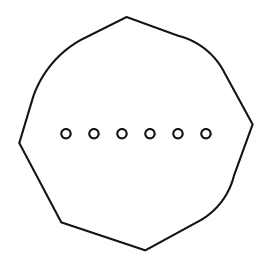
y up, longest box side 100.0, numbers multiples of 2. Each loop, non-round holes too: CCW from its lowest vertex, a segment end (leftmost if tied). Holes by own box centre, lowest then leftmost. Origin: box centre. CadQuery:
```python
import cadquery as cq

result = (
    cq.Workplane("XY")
    .moveTo(4.0, -50.0)
    .lineTo(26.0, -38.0)
    .threePointArc((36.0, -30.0), (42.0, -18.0))
    .lineTo(50.0, 4.0)
    .lineTo(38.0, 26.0)
    .threePointArc((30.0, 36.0), (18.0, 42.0))
    .lineTo(-4.0, 50.0)
    .lineTo(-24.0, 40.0)
    .threePointArc((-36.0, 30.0), (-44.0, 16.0))
    .lineTo(-50.0, -4.0)
    .lineTo(-32.0, -38.0)
    .close()
    .moveTo(-30.0, 0.0)
    .circle(2.0)
    .moveTo(-18.0, 0.0)
    .circle(2.0)
    .moveTo(-6.0, 0.0)
    .circle(2.0)
    .moveTo(6.0, 0.0)
    .circle(2.0)
    .moveTo(18.0, 0.0)
    .circle(2.0)
    .moveTo(30.0, 0.0)
    .circle(2.0)
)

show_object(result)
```